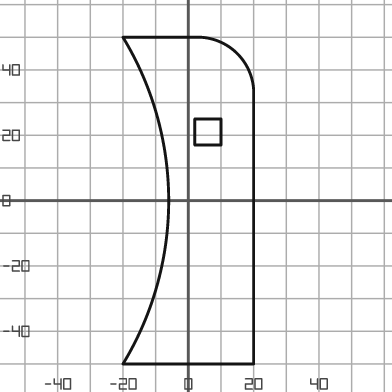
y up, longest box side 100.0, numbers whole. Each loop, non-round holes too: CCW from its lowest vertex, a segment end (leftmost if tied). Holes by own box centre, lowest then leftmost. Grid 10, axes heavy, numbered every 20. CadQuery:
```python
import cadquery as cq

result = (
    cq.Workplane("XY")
    .moveTo(-20.0, -50.0)
    .lineTo(20.0, -50.0)
    .lineTo(20.0, 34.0)
    .threePointArc((15.0, 45.0), (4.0, 50.0))
    .lineTo(-20.0, 50.0)
    .threePointArc((-6.0, 0.0), (-20.0, -50.0))
    .close()
    .moveTo(2.0, 17.0)
    .lineTo(10.0, 17.0)
    .lineTo(10.0, 25.0)
    .lineTo(2.0, 25.0)
    .close()
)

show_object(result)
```